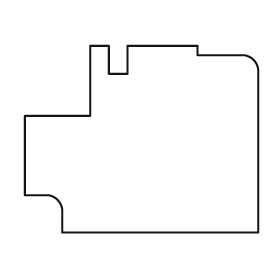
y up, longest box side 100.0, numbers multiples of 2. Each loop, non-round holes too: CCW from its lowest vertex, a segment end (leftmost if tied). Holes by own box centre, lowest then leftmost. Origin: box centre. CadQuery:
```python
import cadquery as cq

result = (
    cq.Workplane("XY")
    .moveTo(-34.0, -40.0)
    .lineTo(50.0, -40.0)
    .lineTo(50.0, 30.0)
    .threePointArc((48.0, 34.0), (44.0, 36.0))
    .lineTo(24.0, 36.0)
    .lineTo(24.0, 40.0)
    .lineTo(-6.0, 40.0)
    .lineTo(-6.0, 28.0)
    .lineTo(-14.0, 28.0)
    .lineTo(-14.0, 40.0)
    .lineTo(-22.0, 40.0)
    .lineTo(-22.0, 10.0)
    .lineTo(-50.0, 10.0)
    .lineTo(-50.0, -24.0)
    .lineTo(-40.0, -24.0)
    .threePointArc((-36.0, -26.0), (-34.0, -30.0))
    .close()
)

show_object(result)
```